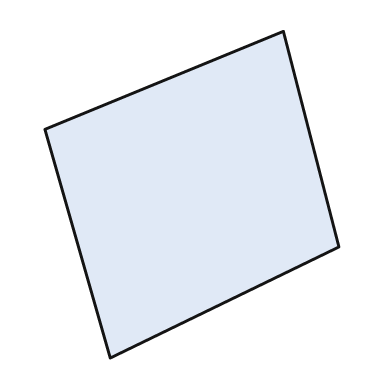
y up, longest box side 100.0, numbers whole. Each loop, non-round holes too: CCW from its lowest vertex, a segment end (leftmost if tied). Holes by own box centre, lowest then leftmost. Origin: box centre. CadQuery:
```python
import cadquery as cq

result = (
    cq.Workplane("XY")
    .moveTo(-25.0, -50.0)
    .lineTo(45.0, -16.0)
    .lineTo(28.0, 50.0)
    .lineTo(-45.0, 20.0)
    .close()
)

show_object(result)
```